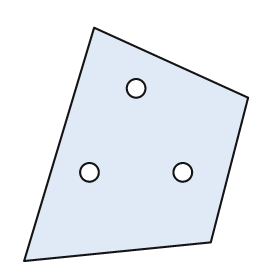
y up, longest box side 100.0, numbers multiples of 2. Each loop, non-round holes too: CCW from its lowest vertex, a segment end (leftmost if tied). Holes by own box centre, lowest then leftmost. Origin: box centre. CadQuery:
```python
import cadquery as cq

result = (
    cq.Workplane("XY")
    .moveTo(-48.0, -50.0)
    .lineTo(32.0, -42.0)
    .lineTo(48.0, 20.0)
    .lineTo(-18.0, 50.0)
    .close()
    .moveTo(-20.0, -12.0)
    .circle(4.0)
    .moveTo(20.0, -12.0)
    .circle(4.0)
    .moveTo(0.0, 24.0)
    .circle(4.0)
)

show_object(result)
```